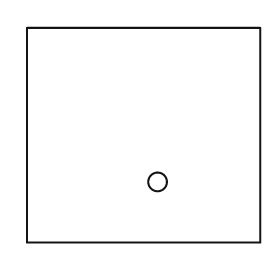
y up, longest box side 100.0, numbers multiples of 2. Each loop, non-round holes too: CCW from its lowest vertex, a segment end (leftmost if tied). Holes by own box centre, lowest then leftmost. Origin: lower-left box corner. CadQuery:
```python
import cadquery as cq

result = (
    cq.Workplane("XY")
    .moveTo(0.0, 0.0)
    .lineTo(100.0, 0.0)
    .lineTo(100.0, 92.0)
    .lineTo(0.0, 92.0)
    .close()
    .moveTo(56.0, 26.0)
    .circle(4.0)
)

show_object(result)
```